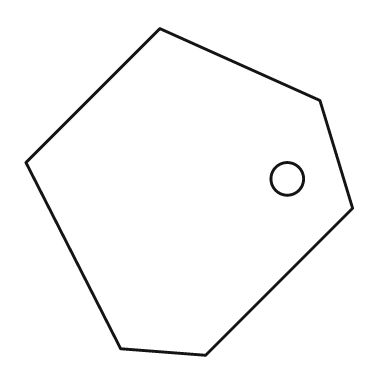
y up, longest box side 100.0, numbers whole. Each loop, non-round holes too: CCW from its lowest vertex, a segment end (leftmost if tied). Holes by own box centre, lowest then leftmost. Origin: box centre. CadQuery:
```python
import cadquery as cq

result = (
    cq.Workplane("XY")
    .moveTo(5.0, -50.0)
    .lineTo(50.0, -5.0)
    .lineTo(40.0, 28.0)
    .lineTo(-9.0, 50.0)
    .lineTo(-50.0, 9.0)
    .lineTo(-21.0, -48.0)
    .close()
    .moveTo(30.0, 4.0)
    .circle(5.0)
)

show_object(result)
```